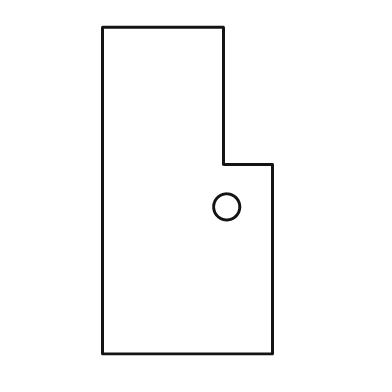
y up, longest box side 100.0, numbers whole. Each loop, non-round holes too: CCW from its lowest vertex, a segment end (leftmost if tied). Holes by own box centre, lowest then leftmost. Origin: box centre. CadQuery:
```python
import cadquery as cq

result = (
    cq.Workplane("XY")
    .moveTo(-26.0, -50.0)
    .lineTo(26.0, -50.0)
    .lineTo(26.0, 8.0)
    .lineTo(11.0, 8.0)
    .lineTo(11.0, 50.0)
    .lineTo(-26.0, 50.0)
    .close()
    .moveTo(12.0, -5.0)
    .circle(4.0)
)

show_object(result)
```